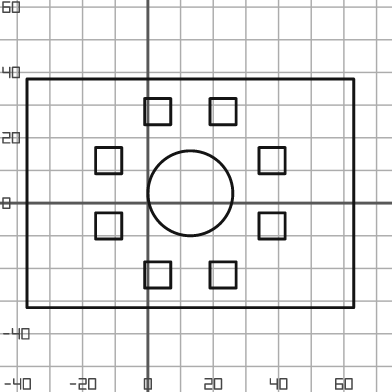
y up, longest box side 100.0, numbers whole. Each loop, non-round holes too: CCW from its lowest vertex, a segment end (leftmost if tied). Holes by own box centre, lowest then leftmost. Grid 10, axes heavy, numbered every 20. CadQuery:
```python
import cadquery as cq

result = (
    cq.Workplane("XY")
    .moveTo(-37.0, -32.0)
    .lineTo(63.0, -32.0)
    .lineTo(63.0, 38.0)
    .lineTo(-37.0, 38.0)
    .close()
    .moveTo(-1.0, -26.0)
    .lineTo(7.0, -26.0)
    .lineTo(7.0, -18.0)
    .lineTo(-1.0, -18.0)
    .close()
    .moveTo(19.0, -26.0)
    .lineTo(27.0, -26.0)
    .lineTo(27.0, -18.0)
    .lineTo(19.0, -18.0)
    .close()
    .moveTo(-16.0, -11.0)
    .lineTo(-8.0, -11.0)
    .lineTo(-8.0, -3.0)
    .lineTo(-16.0, -3.0)
    .close()
    .moveTo(34.0, -11.0)
    .lineTo(42.0, -11.0)
    .lineTo(42.0, -3.0)
    .lineTo(34.0, -3.0)
    .close()
    .moveTo(13.0, 3.0)
    .circle(13.0)
    .moveTo(-16.0, 9.0)
    .lineTo(-8.0, 9.0)
    .lineTo(-8.0, 17.0)
    .lineTo(-16.0, 17.0)
    .close()
    .moveTo(34.0, 9.0)
    .lineTo(42.0, 9.0)
    .lineTo(42.0, 17.0)
    .lineTo(34.0, 17.0)
    .close()
    .moveTo(-1.0, 24.0)
    .lineTo(7.0, 24.0)
    .lineTo(7.0, 32.0)
    .lineTo(-1.0, 32.0)
    .close()
    .moveTo(19.0, 24.0)
    .lineTo(27.0, 24.0)
    .lineTo(27.0, 32.0)
    .lineTo(19.0, 32.0)
    .close()
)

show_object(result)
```